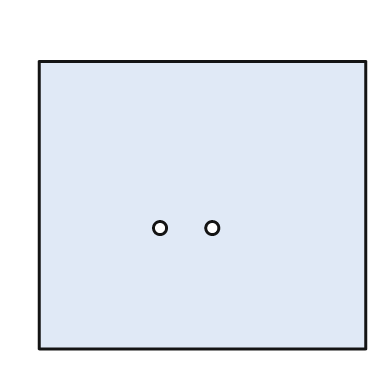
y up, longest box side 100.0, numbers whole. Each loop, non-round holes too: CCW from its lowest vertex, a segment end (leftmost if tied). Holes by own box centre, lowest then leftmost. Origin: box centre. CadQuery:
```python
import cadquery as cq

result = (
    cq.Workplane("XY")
    .moveTo(-50.0, -44.0)
    .lineTo(50.0, -44.0)
    .lineTo(50.0, 44.0)
    .lineTo(-50.0, 44.0)
    .close()
    .moveTo(-13.0, -7.0)
    .circle(2.0)
    .moveTo(3.0, -7.0)
    .circle(2.0)
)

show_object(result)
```